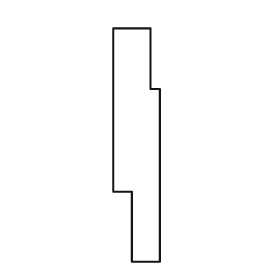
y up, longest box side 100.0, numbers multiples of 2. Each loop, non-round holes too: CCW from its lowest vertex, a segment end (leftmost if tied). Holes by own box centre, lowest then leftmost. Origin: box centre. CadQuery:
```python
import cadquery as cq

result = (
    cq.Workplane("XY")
    .moveTo(-2.0, -50.0)
    .lineTo(10.0, -50.0)
    .lineTo(10.0, 24.0)
    .lineTo(6.0, 24.0)
    .lineTo(6.0, 50.0)
    .lineTo(-10.0, 50.0)
    .lineTo(-10.0, -20.0)
    .lineTo(-2.0, -20.0)
    .close()
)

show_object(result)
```